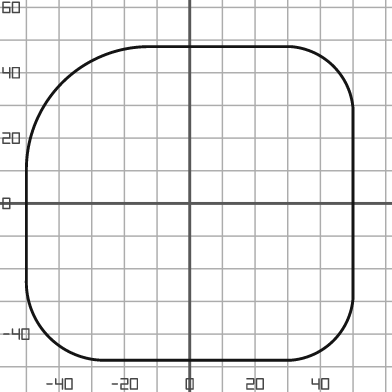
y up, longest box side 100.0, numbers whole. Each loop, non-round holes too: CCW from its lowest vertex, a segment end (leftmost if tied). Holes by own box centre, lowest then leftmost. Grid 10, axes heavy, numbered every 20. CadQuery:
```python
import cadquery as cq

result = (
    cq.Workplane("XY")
    .moveTo(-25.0, -48.0)
    .lineTo(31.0, -48.0)
    .threePointArc((44.0, -42.0), (50.0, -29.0))
    .lineTo(50.0, 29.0)
    .threePointArc((44.0, 42.0), (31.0, 48.0))
    .lineTo(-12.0, 48.0)
    .threePointArc((-39.0, 37.0), (-50.0, 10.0))
    .lineTo(-50.0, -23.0)
    .threePointArc((-43.0, -41.0), (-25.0, -48.0))
    .close()
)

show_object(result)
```